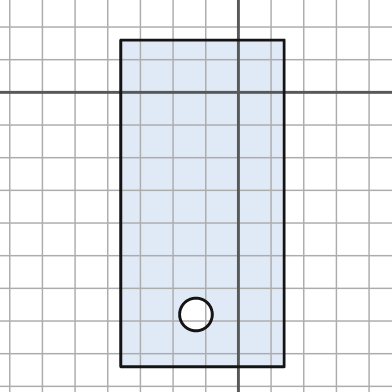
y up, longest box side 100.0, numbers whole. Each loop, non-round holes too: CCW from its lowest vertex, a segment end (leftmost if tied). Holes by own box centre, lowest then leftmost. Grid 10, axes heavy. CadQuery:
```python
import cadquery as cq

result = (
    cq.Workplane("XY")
    .moveTo(-36.0, -84.0)
    .lineTo(14.0, -84.0)
    .lineTo(14.0, 16.0)
    .lineTo(-36.0, 16.0)
    .close()
    .moveTo(-13.0, -68.0)
    .circle(5.0)
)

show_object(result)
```